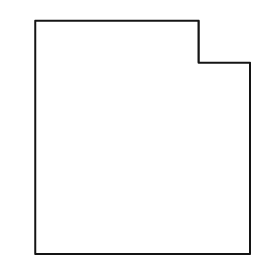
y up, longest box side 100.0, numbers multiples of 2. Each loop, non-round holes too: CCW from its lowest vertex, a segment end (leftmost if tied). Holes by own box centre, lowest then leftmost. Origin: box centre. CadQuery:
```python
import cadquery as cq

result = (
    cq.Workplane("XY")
    .moveTo(-46.0, -50.0)
    .lineTo(46.0, -50.0)
    .lineTo(46.0, 32.0)
    .lineTo(24.0, 32.0)
    .lineTo(24.0, 50.0)
    .lineTo(-46.0, 50.0)
    .close()
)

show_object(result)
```